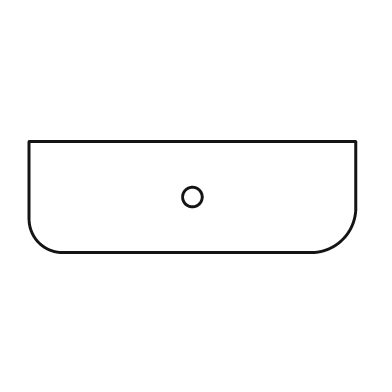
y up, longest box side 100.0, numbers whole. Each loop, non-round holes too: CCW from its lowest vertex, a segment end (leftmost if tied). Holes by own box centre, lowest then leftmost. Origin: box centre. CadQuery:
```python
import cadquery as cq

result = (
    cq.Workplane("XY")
    .moveTo(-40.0, -17.0)
    .lineTo(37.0, -17.0)
    .threePointArc((46.0, -13.0), (50.0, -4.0))
    .lineTo(50.0, 17.0)
    .lineTo(-50.0, 17.0)
    .lineTo(-50.0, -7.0)
    .threePointArc((-47.0, -14.0), (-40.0, -17.0))
    .close()
    .moveTo(0.0, 0.0)
    .circle(3.0)
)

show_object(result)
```